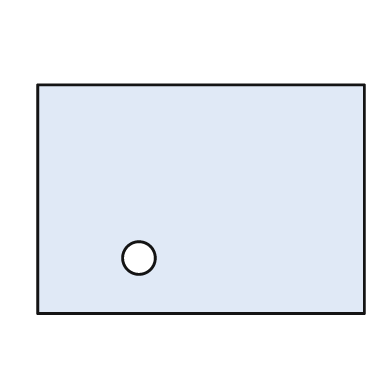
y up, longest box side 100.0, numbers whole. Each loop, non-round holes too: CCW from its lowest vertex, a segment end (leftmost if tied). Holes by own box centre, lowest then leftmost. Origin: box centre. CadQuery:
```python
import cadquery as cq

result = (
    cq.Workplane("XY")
    .moveTo(-50.0, -35.0)
    .lineTo(50.0, -35.0)
    .lineTo(50.0, 35.0)
    .lineTo(-50.0, 35.0)
    .close()
    .moveTo(-19.0, -18.0)
    .circle(5.0)
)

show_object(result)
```